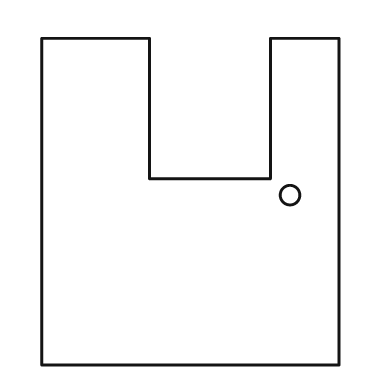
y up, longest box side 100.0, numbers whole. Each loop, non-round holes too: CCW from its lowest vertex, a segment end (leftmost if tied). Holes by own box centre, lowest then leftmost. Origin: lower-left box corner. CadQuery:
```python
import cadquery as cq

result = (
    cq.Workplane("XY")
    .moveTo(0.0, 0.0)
    .lineTo(91.0, 0.0)
    .lineTo(91.0, 100.0)
    .lineTo(70.0, 100.0)
    .lineTo(70.0, 57.0)
    .lineTo(33.0, 57.0)
    .lineTo(33.0, 100.0)
    .lineTo(0.0, 100.0)
    .close()
    .moveTo(76.0, 52.0)
    .circle(3.0)
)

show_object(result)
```